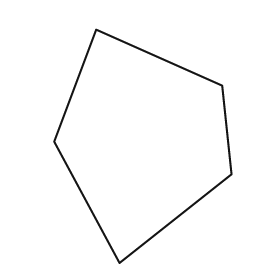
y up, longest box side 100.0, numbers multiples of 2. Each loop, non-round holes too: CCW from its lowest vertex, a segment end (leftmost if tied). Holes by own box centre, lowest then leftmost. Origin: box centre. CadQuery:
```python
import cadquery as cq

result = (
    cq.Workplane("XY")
    .moveTo(-10.0, -50.0)
    .lineTo(38.0, -12.0)
    .lineTo(34.0, 26.0)
    .lineTo(-20.0, 50.0)
    .lineTo(-38.0, 2.0)
    .close()
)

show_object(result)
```